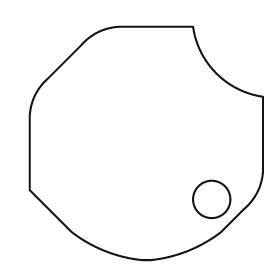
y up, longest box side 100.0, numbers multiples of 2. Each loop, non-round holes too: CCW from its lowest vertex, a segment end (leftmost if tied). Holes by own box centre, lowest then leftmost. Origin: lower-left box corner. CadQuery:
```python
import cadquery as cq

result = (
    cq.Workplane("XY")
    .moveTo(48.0, 0.0)
    .lineTo(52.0, 0.0)
    .threePointArc((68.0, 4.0), (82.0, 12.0))
    .lineTo(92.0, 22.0)
    .threePointArc((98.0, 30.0), (100.0, 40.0))
    .lineTo(100.0, 70.0)
    .threePointArc((80.0, 80.0), (70.0, 100.0))
    .lineTo(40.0, 100.0)
    .threePointArc((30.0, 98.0), (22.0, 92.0))
    .lineTo(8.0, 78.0)
    .threePointArc((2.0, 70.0), (0.0, 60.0))
    .lineTo(0.0, 30.0)
    .lineTo(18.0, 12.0)
    .threePointArc((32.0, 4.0), (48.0, 0.0))
    .close()
    .moveTo(78.0, 26.0)
    .circle(8.0)
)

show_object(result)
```